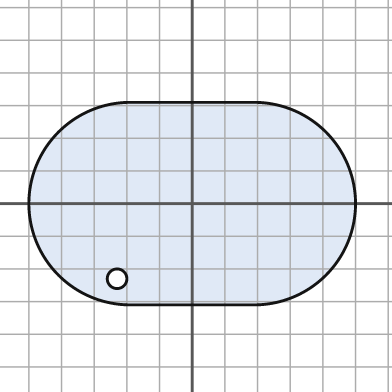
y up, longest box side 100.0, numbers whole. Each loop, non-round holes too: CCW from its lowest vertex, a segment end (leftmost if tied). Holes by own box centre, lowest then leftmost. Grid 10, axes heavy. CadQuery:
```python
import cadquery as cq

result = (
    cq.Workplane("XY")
    .moveTo(-19.0, -31.0)
    .lineTo(19.0, -31.0)
    .threePointArc((50.0, 0.0), (19.0, 31.0))
    .lineTo(-19.0, 31.0)
    .threePointArc((-50.0, 0.0), (-19.0, -31.0))
    .close()
    .moveTo(-23.0, -23.0)
    .circle(3.0)
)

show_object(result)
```